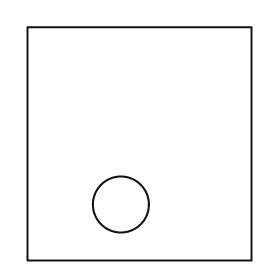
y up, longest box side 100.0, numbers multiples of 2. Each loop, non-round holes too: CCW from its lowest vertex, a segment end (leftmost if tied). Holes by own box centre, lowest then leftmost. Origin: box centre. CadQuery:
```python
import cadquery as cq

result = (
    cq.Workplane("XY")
    .moveTo(-48.0, -50.0)
    .lineTo(48.0, -50.0)
    .lineTo(48.0, 50.0)
    .lineTo(-48.0, 50.0)
    .close()
    .moveTo(-8.0, -26.0)
    .circle(12.0)
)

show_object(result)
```